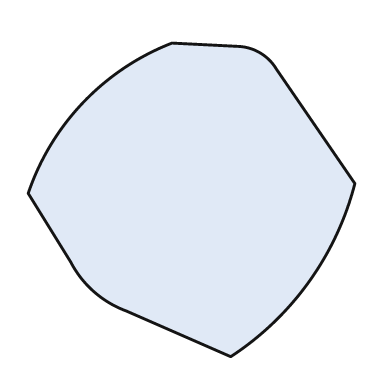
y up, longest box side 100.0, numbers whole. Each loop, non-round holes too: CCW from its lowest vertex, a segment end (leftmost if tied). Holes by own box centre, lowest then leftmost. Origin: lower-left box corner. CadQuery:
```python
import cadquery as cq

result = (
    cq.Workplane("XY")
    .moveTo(62.0, 0.0)
    .threePointArc((86.0, 23.0), (100.0, 53.0))
    .lineTo(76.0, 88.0)
    .threePointArc((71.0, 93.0), (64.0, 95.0))
    .lineTo(44.0, 96.0)
    .threePointArc((17.0, 78.0), (0.0, 50.0))
    .lineTo(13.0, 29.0)
    .threePointArc((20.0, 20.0), (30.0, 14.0))
    .close()
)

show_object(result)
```